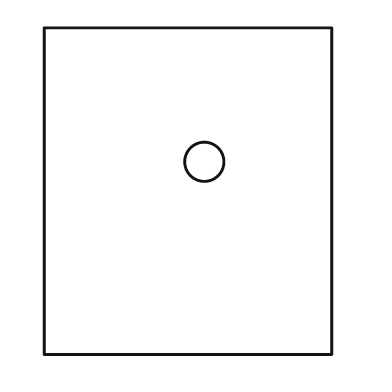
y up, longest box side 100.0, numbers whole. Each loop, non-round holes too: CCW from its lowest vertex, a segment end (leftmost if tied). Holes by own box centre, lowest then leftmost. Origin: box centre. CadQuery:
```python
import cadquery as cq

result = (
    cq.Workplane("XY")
    .moveTo(-44.0, -50.0)
    .lineTo(44.0, -50.0)
    .lineTo(44.0, 50.0)
    .lineTo(-44.0, 50.0)
    .close()
    .moveTo(5.0, 9.0)
    .circle(6.0)
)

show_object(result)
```